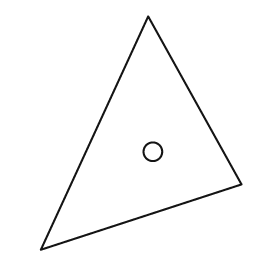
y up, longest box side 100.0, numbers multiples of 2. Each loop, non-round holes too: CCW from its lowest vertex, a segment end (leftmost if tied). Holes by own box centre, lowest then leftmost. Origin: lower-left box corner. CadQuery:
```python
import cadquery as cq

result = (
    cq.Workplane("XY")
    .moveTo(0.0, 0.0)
    .lineTo(86.0, 28.0)
    .lineTo(46.0, 100.0)
    .close()
    .moveTo(48.0, 42.0)
    .circle(4.0)
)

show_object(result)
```